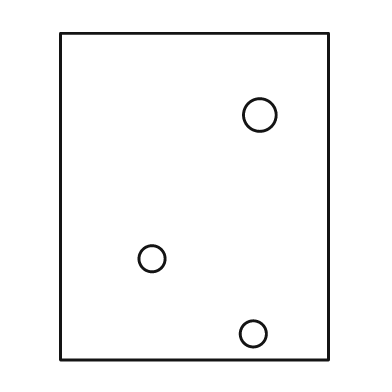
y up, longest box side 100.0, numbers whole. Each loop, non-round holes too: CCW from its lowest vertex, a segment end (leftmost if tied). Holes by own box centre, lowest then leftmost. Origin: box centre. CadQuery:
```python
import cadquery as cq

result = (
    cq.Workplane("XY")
    .moveTo(-41.0, -50.0)
    .lineTo(41.0, -50.0)
    .lineTo(41.0, 50.0)
    .lineTo(-41.0, 50.0)
    .close()
    .moveTo(18.0, -42.0)
    .circle(4.0)
    .moveTo(-13.0, -19.0)
    .circle(4.0)
    .moveTo(20.0, 25.0)
    .circle(5.0)
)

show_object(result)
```